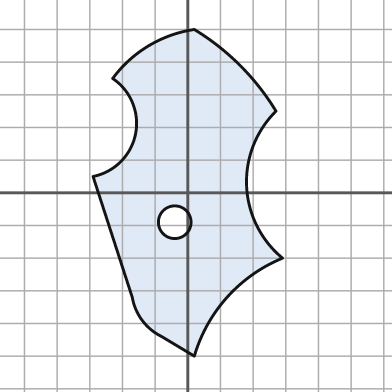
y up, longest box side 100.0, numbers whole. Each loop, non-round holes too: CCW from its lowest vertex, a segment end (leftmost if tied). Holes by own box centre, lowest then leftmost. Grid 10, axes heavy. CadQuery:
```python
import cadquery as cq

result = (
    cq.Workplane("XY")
    .moveTo(2.0, -50.0)
    .threePointArc((12.0, -32.0), (29.0, -20.0))
    .threePointArc((18.0, 2.0), (27.0, 25.0))
    .threePointArc((16.0, 39.0), (2.0, 50.0))
    .threePointArc((-12.0, 45.0), (-23.0, 35.0))
    .threePointArc((-16.0, 18.0), (-29.0, 5.0))
    .lineTo(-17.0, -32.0)
    .threePointArc((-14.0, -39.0), (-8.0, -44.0))
    .close()
    .moveTo(-4.0, -9.0)
    .circle(5.0)
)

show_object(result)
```